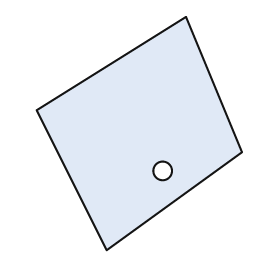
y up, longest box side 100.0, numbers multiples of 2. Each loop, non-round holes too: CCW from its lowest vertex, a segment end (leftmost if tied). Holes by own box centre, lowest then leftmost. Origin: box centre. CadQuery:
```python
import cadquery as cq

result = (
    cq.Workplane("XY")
    .moveTo(-14.0, -50.0)
    .lineTo(44.0, -8.0)
    .lineTo(20.0, 50.0)
    .lineTo(-44.0, 10.0)
    .close()
    .moveTo(10.0, -16.0)
    .circle(4.0)
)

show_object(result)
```